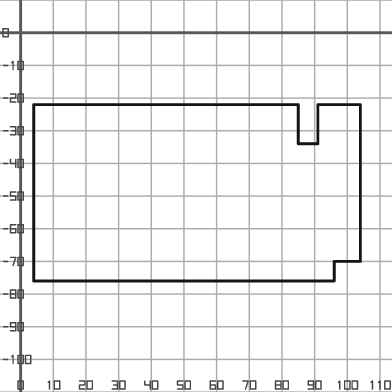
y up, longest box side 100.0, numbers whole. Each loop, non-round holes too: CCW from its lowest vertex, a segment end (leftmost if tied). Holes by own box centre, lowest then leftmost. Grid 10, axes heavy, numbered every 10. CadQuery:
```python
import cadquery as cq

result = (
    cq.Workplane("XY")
    .moveTo(4.0, -76.0)
    .lineTo(96.0, -76.0)
    .lineTo(96.0, -70.0)
    .lineTo(104.0, -70.0)
    .lineTo(104.0, -22.0)
    .lineTo(91.0, -22.0)
    .lineTo(91.0, -34.0)
    .lineTo(85.0, -34.0)
    .lineTo(85.0, -22.0)
    .lineTo(4.0, -22.0)
    .close()
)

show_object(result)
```